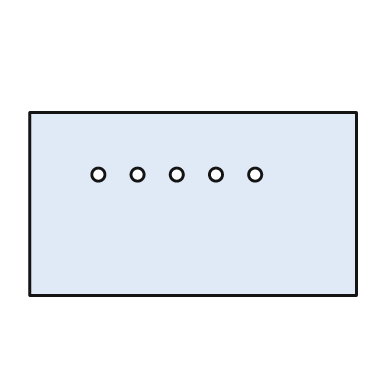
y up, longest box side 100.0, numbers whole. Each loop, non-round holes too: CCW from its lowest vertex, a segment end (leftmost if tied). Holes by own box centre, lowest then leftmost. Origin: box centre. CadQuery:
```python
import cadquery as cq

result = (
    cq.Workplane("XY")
    .moveTo(-50.0, -28.0)
    .lineTo(50.0, -28.0)
    .lineTo(50.0, 28.0)
    .lineTo(-50.0, 28.0)
    .close()
    .moveTo(-29.0, 9.0)
    .circle(2.0)
    .moveTo(-17.0, 9.0)
    .circle(2.0)
    .moveTo(-5.0, 9.0)
    .circle(2.0)
    .moveTo(7.0, 9.0)
    .circle(2.0)
    .moveTo(19.0, 9.0)
    .circle(2.0)
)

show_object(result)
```